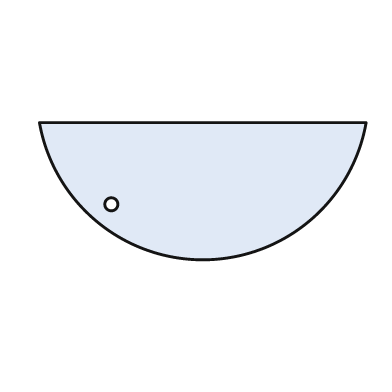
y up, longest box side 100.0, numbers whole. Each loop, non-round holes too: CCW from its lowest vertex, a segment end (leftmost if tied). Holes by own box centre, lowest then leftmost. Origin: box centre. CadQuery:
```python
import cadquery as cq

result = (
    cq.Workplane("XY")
    .moveTo(-50.0, 21.0)
    .threePointArc((0.0, -21.0), (50.0, 21.0))
    .close()
    .moveTo(-28.0, -4.0)
    .circle(2.0)
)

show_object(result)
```